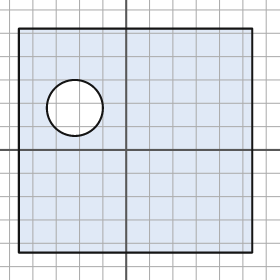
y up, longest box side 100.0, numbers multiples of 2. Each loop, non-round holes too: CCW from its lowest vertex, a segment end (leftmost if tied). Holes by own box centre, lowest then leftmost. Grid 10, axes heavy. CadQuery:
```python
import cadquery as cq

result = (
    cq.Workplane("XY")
    .moveTo(-46.0, -44.0)
    .lineTo(54.0, -44.0)
    .lineTo(54.0, 52.0)
    .lineTo(-46.0, 52.0)
    .close()
    .moveTo(-22.0, 18.0)
    .circle(12.0)
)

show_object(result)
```